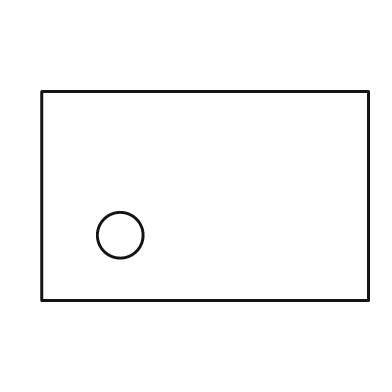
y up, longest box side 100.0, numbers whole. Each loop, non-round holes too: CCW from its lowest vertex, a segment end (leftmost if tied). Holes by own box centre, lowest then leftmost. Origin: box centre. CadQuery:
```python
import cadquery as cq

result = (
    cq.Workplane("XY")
    .moveTo(-50.0, -32.0)
    .lineTo(50.0, -32.0)
    .lineTo(50.0, 32.0)
    .lineTo(-50.0, 32.0)
    .close()
    .moveTo(-26.0, -12.0)
    .circle(7.0)
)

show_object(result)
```